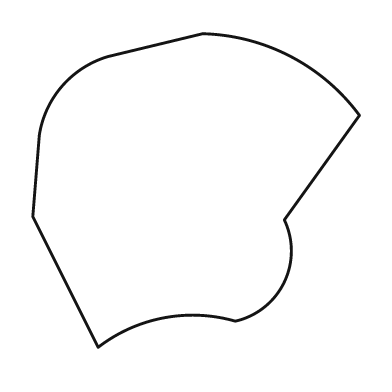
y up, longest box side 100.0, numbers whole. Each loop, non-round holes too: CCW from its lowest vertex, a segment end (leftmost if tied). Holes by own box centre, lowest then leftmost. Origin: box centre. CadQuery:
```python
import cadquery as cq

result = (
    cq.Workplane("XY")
    .moveTo(-30.0, -48.0)
    .threePointArc((-10.0, -39.0), (12.0, -40.0))
    .threePointArc((27.0, -28.0), (27.0, -9.0))
    .lineTo(50.0, 23.0)
    .threePointArc((29.0, 41.0), (2.0, 48.0))
    .lineTo(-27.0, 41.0)
    .threePointArc((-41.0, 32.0), (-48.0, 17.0))
    .lineTo(-50.0, -8.0)
    .close()
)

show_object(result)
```